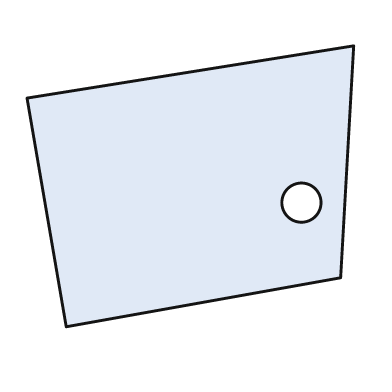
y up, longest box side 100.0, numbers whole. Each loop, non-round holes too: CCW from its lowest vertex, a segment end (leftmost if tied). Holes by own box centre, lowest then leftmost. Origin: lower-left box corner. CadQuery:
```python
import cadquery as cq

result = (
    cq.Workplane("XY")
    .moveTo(12.0, 0.0)
    .lineTo(96.0, 15.0)
    .lineTo(100.0, 86.0)
    .lineTo(0.0, 70.0)
    .close()
    .moveTo(84.0, 38.0)
    .circle(6.0)
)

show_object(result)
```